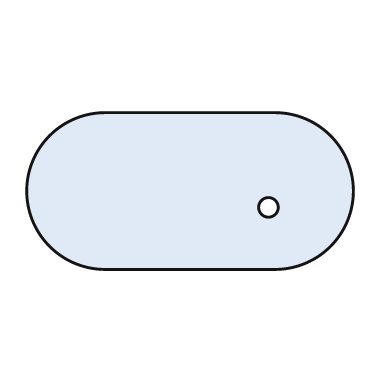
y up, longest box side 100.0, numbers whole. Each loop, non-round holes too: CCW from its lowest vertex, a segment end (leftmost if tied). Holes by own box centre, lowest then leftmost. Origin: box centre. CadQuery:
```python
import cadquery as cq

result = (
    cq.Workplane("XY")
    .moveTo(-26.0, -24.0)
    .lineTo(26.0, -24.0)
    .threePointArc((50.0, 0.0), (26.0, 24.0))
    .lineTo(-26.0, 24.0)
    .threePointArc((-50.0, 0.0), (-26.0, -24.0))
    .close()
    .moveTo(24.0, -5.0)
    .circle(3.0)
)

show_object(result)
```